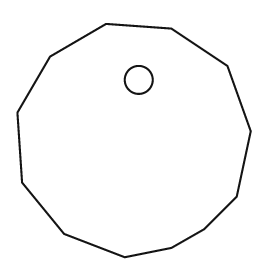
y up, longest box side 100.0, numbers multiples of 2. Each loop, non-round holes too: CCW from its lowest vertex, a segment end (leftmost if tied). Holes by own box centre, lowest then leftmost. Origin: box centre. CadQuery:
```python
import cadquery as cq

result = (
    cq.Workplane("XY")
    .moveTo(-4.0, -50.0)
    .lineTo(16.0, -46.0)
    .lineTo(30.0, -38.0)
    .lineTo(44.0, -24.0)
    .lineTo(50.0, 4.0)
    .lineTo(40.0, 32.0)
    .lineTo(16.0, 48.0)
    .lineTo(-12.0, 50.0)
    .lineTo(-36.0, 36.0)
    .lineTo(-50.0, 12.0)
    .lineTo(-48.0, -18.0)
    .lineTo(-30.0, -40.0)
    .close()
    .moveTo(2.0, 26.0)
    .circle(6.0)
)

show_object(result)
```